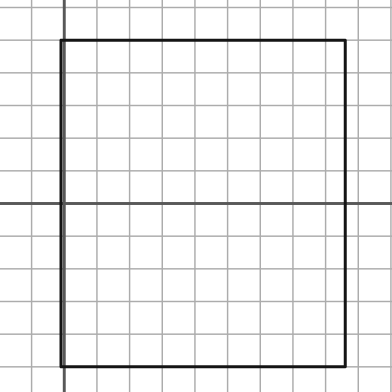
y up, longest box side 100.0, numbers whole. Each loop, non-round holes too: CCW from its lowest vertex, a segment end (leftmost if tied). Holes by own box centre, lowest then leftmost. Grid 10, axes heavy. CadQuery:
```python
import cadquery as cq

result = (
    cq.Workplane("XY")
    .moveTo(-1.0, -50.0)
    .lineTo(86.0, -50.0)
    .lineTo(86.0, 50.0)
    .lineTo(-1.0, 50.0)
    .close()
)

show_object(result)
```